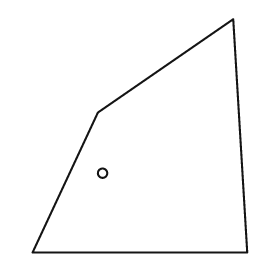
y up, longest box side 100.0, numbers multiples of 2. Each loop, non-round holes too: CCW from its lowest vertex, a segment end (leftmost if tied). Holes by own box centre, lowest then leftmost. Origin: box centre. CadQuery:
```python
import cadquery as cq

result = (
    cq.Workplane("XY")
    .moveTo(-46.0, -50.0)
    .lineTo(46.0, -50.0)
    .lineTo(40.0, 50.0)
    .lineTo(-18.0, 10.0)
    .close()
    .moveTo(-16.0, -16.0)
    .circle(2.0)
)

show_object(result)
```